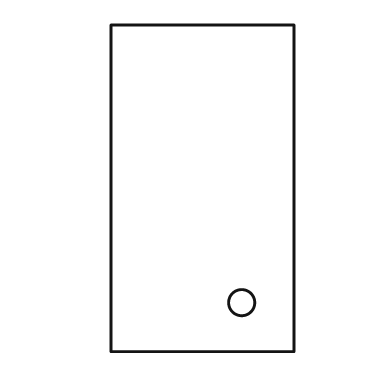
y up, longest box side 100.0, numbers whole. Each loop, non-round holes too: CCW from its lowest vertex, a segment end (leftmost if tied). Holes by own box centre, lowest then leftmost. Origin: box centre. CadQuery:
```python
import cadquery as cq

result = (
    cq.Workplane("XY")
    .moveTo(-28.0, -50.0)
    .lineTo(28.0, -50.0)
    .lineTo(28.0, 50.0)
    .lineTo(-28.0, 50.0)
    .close()
    .moveTo(12.0, -35.0)
    .circle(4.0)
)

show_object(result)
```